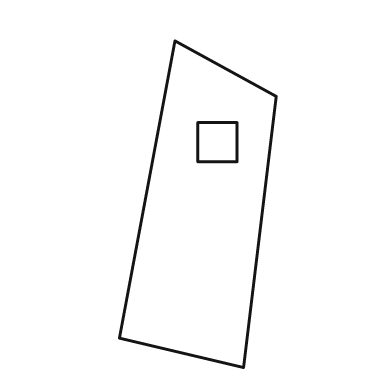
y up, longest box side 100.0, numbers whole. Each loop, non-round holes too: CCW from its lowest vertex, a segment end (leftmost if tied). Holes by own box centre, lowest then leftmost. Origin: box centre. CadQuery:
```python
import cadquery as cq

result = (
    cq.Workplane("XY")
    .moveTo(14.0, -50.0)
    .lineTo(24.0, 33.0)
    .lineTo(-7.0, 50.0)
    .lineTo(-24.0, -41.0)
    .close()
    .moveTo(0.0, 13.0)
    .lineTo(12.0, 13.0)
    .lineTo(12.0, 25.0)
    .lineTo(0.0, 25.0)
    .close()
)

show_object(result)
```